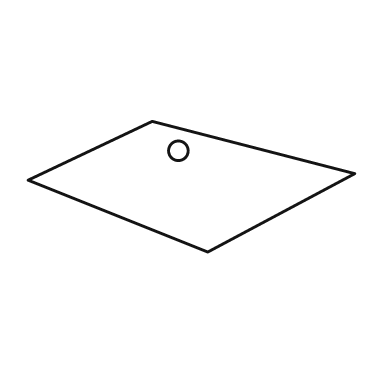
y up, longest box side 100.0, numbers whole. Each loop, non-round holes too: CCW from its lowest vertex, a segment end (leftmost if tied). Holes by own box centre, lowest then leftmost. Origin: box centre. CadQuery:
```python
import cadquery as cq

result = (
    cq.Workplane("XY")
    .moveTo(5.0, -20.0)
    .lineTo(50.0, 4.0)
    .lineTo(-12.0, 20.0)
    .lineTo(-50.0, 2.0)
    .close()
    .moveTo(-4.0, 11.0)
    .circle(3.0)
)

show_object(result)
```